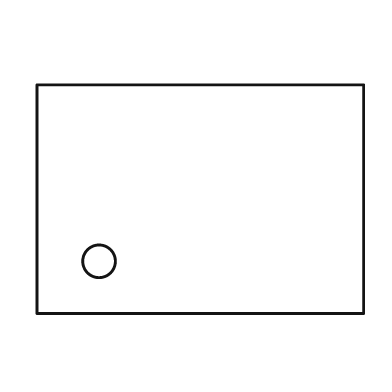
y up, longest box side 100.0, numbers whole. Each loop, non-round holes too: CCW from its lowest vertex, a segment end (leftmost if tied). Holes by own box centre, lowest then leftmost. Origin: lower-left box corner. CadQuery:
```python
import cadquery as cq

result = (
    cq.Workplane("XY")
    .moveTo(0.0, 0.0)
    .lineTo(100.0, 0.0)
    .lineTo(100.0, 70.0)
    .lineTo(0.0, 70.0)
    .close()
    .moveTo(19.0, 16.0)
    .circle(5.0)
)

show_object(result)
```